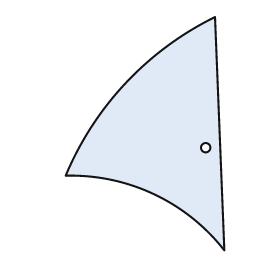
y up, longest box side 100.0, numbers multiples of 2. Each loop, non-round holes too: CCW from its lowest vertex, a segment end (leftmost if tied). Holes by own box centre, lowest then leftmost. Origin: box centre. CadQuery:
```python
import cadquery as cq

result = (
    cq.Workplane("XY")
    .moveTo(34.0, -50.0)
    .lineTo(30.0, 50.0)
    .threePointArc((-8.0, 22.0), (-34.0, -18.0))
    .threePointArc((4.0, -26.0), (34.0, -50.0))
    .close()
    .moveTo(26.0, -6.0)
    .circle(2.0)
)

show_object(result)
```